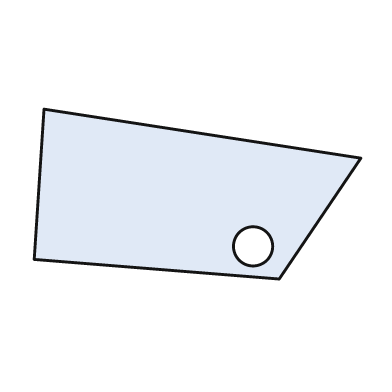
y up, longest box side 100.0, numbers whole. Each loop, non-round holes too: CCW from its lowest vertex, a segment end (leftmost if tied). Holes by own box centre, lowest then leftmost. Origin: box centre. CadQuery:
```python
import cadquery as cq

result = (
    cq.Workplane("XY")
    .moveTo(25.0, -26.0)
    .lineTo(50.0, 11.0)
    .lineTo(-47.0, 26.0)
    .lineTo(-50.0, -20.0)
    .close()
    .moveTo(17.0, -16.0)
    .circle(6.0)
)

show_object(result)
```